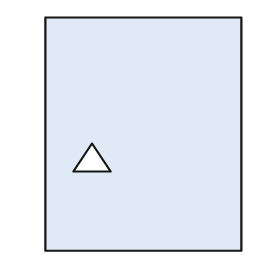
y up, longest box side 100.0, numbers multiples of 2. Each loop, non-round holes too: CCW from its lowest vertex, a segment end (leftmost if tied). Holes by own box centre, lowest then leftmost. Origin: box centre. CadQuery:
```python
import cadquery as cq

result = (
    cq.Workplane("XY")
    .moveTo(-42.0, -50.0)
    .lineTo(42.0, -50.0)
    .lineTo(42.0, 50.0)
    .lineTo(-42.0, 50.0)
    .close()
    .moveTo(-30.0, -16.0)
    .lineTo(-14.0, -16.0)
    .lineTo(-22.0, -4.0)
    .close()
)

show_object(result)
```